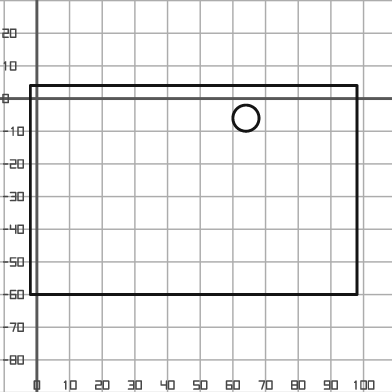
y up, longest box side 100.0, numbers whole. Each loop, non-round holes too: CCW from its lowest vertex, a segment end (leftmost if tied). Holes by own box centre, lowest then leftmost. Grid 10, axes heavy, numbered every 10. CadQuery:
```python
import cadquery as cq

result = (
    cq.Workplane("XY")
    .moveTo(-2.0, -60.0)
    .lineTo(98.0, -60.0)
    .lineTo(98.0, 4.0)
    .lineTo(-2.0, 4.0)
    .close()
    .moveTo(64.0, -6.0)
    .circle(4.0)
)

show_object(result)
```